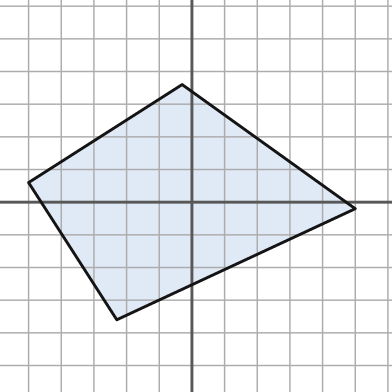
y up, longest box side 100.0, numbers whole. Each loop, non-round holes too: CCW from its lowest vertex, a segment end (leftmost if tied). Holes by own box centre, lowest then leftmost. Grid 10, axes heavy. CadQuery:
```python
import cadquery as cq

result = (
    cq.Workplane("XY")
    .moveTo(-23.0, -36.0)
    .lineTo(50.0, -2.0)
    .lineTo(-3.0, 36.0)
    .lineTo(-50.0, 6.0)
    .close()
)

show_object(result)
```